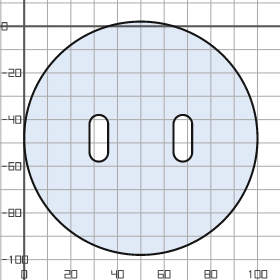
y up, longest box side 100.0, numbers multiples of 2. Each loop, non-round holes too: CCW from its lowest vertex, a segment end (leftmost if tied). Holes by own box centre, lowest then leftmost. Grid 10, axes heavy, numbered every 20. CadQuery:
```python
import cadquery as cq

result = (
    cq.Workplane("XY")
    .moveTo(50.0, -48.0)
    .circle(50.0)
    .moveTo(28.0, -54.0)
    .threePointArc((32.0, -58.0), (36.0, -54.0))
    .lineTo(36.0, -42.0)
    .threePointArc((32.0, -38.0), (28.0, -42.0))
    .close()
    .moveTo(64.0, -54.0)
    .threePointArc((68.0, -58.0), (72.0, -54.0))
    .lineTo(72.0, -42.0)
    .threePointArc((68.0, -38.0), (64.0, -42.0))
    .close()
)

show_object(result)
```